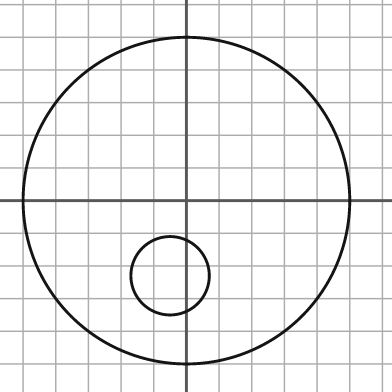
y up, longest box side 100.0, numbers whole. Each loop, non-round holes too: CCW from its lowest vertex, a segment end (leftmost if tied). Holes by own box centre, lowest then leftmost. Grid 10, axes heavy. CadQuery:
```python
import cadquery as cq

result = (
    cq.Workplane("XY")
    .moveTo(0.0, 0.0)
    .circle(50.0)
    .moveTo(-5.0, -23.0)
    .circle(12.0)
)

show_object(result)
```